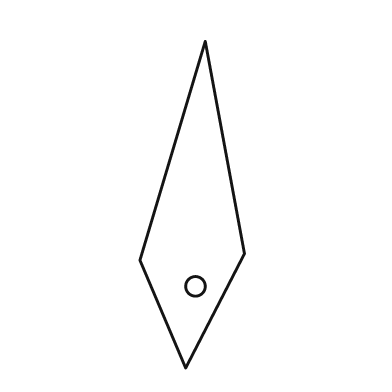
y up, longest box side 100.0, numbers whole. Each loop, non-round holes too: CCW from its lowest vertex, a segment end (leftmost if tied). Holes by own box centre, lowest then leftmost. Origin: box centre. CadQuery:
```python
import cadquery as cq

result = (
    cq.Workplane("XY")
    .moveTo(-2.0, -50.0)
    .lineTo(16.0, -15.0)
    .lineTo(4.0, 50.0)
    .lineTo(-16.0, -17.0)
    .close()
    .moveTo(1.0, -25.0)
    .circle(3.0)
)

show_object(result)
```